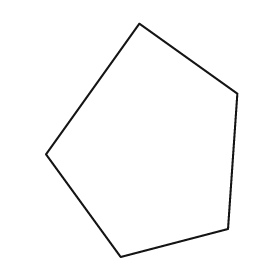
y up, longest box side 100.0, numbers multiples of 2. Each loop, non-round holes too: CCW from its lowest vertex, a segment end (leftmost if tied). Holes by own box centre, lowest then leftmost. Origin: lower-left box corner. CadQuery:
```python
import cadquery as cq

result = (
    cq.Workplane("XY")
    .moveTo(32.0, 0.0)
    .lineTo(78.0, 12.0)
    .lineTo(82.0, 70.0)
    .lineTo(40.0, 100.0)
    .lineTo(0.0, 44.0)
    .close()
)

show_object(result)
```